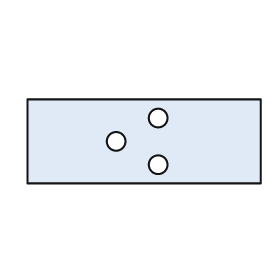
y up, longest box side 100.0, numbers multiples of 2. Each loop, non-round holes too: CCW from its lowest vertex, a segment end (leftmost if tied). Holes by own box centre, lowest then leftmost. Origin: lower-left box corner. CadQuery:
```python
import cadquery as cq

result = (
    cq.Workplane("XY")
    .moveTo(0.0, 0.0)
    .lineTo(100.0, 0.0)
    .lineTo(100.0, 36.0)
    .lineTo(0.0, 36.0)
    .close()
    .moveTo(56.0, 8.0)
    .circle(4.0)
    .moveTo(38.0, 18.0)
    .circle(4.0)
    .moveTo(56.0, 28.0)
    .circle(4.0)
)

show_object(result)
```